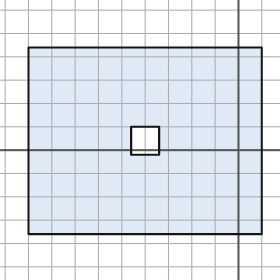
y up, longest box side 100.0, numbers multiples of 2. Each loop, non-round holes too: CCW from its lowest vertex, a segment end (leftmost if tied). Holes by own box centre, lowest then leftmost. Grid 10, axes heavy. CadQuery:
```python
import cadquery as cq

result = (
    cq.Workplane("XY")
    .moveTo(-90.0, -36.0)
    .lineTo(10.0, -36.0)
    .lineTo(10.0, 44.0)
    .lineTo(-90.0, 44.0)
    .close()
    .moveTo(-46.0, -2.0)
    .lineTo(-34.0, -2.0)
    .lineTo(-34.0, 10.0)
    .lineTo(-46.0, 10.0)
    .close()
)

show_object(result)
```